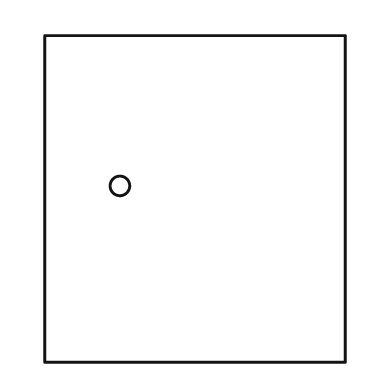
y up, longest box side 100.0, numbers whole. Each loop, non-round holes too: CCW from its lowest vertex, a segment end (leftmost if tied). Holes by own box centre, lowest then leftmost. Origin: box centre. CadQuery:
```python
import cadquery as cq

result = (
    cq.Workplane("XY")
    .moveTo(-46.0, -50.0)
    .lineTo(46.0, -50.0)
    .lineTo(46.0, 50.0)
    .lineTo(-46.0, 50.0)
    .close()
    .moveTo(-23.0, 4.0)
    .circle(3.0)
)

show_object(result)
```